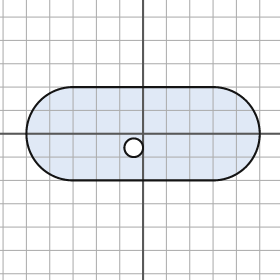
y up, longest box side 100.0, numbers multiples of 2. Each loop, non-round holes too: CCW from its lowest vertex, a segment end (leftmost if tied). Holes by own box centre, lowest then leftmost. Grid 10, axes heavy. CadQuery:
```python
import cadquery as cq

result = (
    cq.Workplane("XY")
    .moveTo(-30.0, -20.0)
    .lineTo(30.0, -20.0)
    .threePointArc((50.0, 0.0), (30.0, 20.0))
    .lineTo(-30.0, 20.0)
    .threePointArc((-50.0, 0.0), (-30.0, -20.0))
    .close()
    .moveTo(-4.0, -6.0)
    .circle(4.0)
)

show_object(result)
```